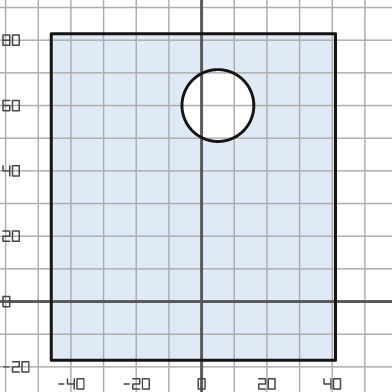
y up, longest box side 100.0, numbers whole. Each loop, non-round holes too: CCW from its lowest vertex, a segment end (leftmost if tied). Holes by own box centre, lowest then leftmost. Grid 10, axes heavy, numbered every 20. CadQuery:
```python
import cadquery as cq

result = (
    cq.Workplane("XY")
    .moveTo(-46.0, -18.0)
    .lineTo(41.0, -18.0)
    .lineTo(41.0, 82.0)
    .lineTo(-46.0, 82.0)
    .close()
    .moveTo(5.0, 60.0)
    .circle(11.0)
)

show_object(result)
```